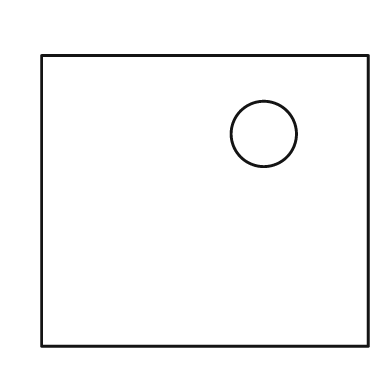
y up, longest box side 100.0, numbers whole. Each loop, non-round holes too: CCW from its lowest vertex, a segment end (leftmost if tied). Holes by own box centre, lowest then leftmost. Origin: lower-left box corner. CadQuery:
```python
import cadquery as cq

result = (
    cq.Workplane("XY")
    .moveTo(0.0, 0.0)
    .lineTo(100.0, 0.0)
    .lineTo(100.0, 89.0)
    .lineTo(0.0, 89.0)
    .close()
    .moveTo(68.0, 65.0)
    .circle(10.0)
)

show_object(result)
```